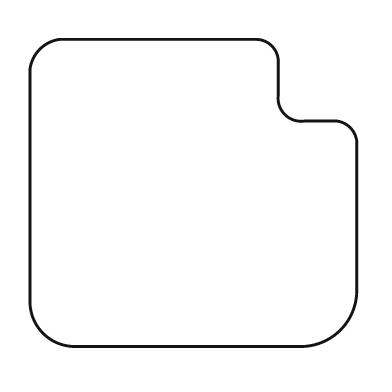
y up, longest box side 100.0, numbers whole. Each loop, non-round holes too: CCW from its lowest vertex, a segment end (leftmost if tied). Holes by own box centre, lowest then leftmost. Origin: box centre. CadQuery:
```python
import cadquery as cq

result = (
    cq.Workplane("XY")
    .moveTo(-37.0, -47.0)
    .lineTo(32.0, -47.0)
    .threePointArc((45.0, -42.0), (50.0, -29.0))
    .lineTo(50.0, 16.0)
    .threePointArc((48.0, 20.0), (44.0, 22.0))
    .lineTo(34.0, 22.0)
    .threePointArc((28.0, 24.0), (26.0, 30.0))
    .lineTo(26.0, 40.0)
    .threePointArc((24.0, 45.0), (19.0, 47.0))
    .lineTo(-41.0, 47.0)
    .threePointArc((-47.0, 44.0), (-50.0, 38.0))
    .lineTo(-50.0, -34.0)
    .threePointArc((-46.0, -43.0), (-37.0, -47.0))
    .close()
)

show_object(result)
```